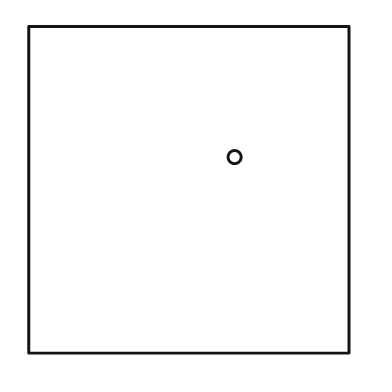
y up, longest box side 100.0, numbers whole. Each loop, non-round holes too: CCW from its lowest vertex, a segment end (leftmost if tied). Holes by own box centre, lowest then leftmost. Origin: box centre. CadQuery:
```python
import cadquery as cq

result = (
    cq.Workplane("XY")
    .moveTo(-49.0, -50.0)
    .lineTo(49.0, -50.0)
    .lineTo(49.0, 50.0)
    .lineTo(-49.0, 50.0)
    .close()
    .moveTo(14.0, 10.0)
    .circle(2.0)
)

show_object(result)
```